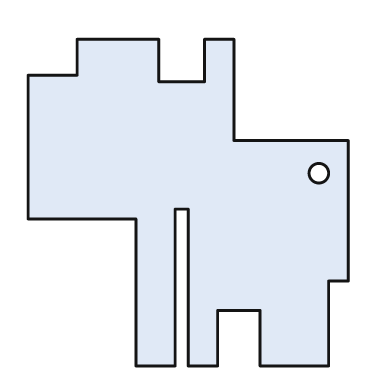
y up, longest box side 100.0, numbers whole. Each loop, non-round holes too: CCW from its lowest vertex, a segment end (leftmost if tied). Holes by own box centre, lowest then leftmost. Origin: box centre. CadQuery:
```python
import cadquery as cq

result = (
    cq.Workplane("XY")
    .moveTo(-16.0, -50.0)
    .lineTo(-4.0, -50.0)
    .lineTo(-4.0, -2.0)
    .lineTo(0.0, -2.0)
    .lineTo(0.0, -50.0)
    .lineTo(9.0, -50.0)
    .lineTo(9.0, -33.0)
    .lineTo(22.0, -33.0)
    .lineTo(22.0, -50.0)
    .lineTo(43.0, -50.0)
    .lineTo(43.0, -24.0)
    .lineTo(49.0, -24.0)
    .lineTo(49.0, 19.0)
    .lineTo(14.0, 19.0)
    .lineTo(14.0, 50.0)
    .lineTo(5.0, 50.0)
    .lineTo(5.0, 37.0)
    .lineTo(-9.0, 37.0)
    .lineTo(-9.0, 50.0)
    .lineTo(-34.0, 50.0)
    .lineTo(-34.0, 39.0)
    .lineTo(-49.0, 39.0)
    .lineTo(-49.0, -5.0)
    .lineTo(-16.0, -5.0)
    .close()
    .moveTo(40.0, 9.0)
    .circle(3.0)
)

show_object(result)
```